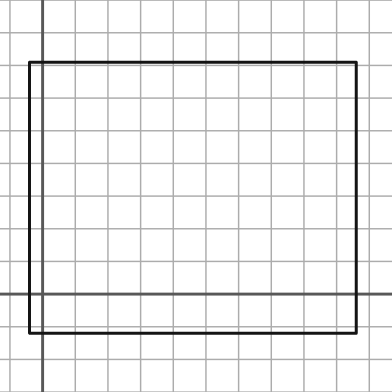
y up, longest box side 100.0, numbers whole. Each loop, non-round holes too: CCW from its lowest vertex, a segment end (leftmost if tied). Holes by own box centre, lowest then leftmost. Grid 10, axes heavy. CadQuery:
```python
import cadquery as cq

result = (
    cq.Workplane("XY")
    .moveTo(-4.0, -12.0)
    .lineTo(96.0, -12.0)
    .lineTo(96.0, 71.0)
    .lineTo(-4.0, 71.0)
    .close()
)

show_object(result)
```